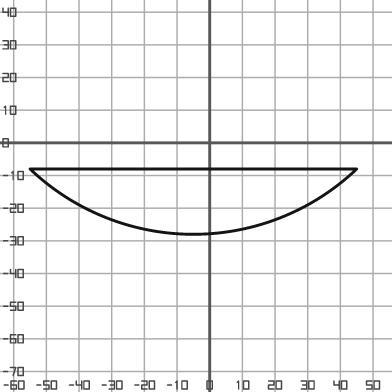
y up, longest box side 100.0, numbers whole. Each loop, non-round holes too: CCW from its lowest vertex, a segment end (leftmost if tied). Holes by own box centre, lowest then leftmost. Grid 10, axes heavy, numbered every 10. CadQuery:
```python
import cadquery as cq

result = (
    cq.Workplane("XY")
    .moveTo(-55.0, -8.0)
    .threePointArc((-5.0, -28.0), (45.0, -8.0))
    .close()
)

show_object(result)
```